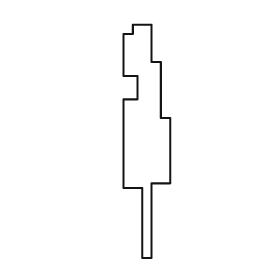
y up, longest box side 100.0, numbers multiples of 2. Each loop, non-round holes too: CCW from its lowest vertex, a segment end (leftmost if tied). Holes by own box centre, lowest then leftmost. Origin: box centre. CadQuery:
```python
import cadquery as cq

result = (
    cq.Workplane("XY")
    .moveTo(-2.0, -50.0)
    .lineTo(2.0, -50.0)
    .lineTo(2.0, -18.0)
    .lineTo(10.0, -18.0)
    .lineTo(10.0, 10.0)
    .lineTo(6.0, 10.0)
    .lineTo(6.0, 34.0)
    .lineTo(2.0, 34.0)
    .lineTo(2.0, 50.0)
    .lineTo(-6.0, 50.0)
    .lineTo(-6.0, 46.0)
    .lineTo(-10.0, 46.0)
    .lineTo(-10.0, 28.0)
    .lineTo(-4.0, 28.0)
    .lineTo(-4.0, 18.0)
    .lineTo(-10.0, 18.0)
    .lineTo(-10.0, -20.0)
    .lineTo(-2.0, -20.0)
    .close()
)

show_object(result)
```